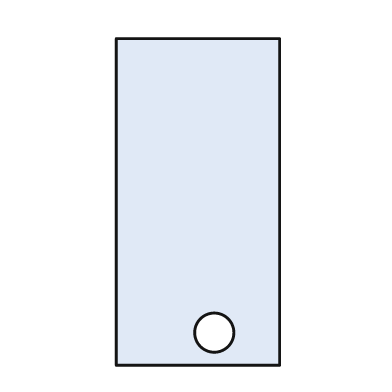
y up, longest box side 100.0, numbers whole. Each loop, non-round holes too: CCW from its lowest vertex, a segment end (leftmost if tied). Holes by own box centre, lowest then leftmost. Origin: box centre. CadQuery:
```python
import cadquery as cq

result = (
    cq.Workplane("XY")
    .moveTo(-25.0, -50.0)
    .lineTo(25.0, -50.0)
    .lineTo(25.0, 50.0)
    .lineTo(-25.0, 50.0)
    .close()
    .moveTo(5.0, -40.0)
    .circle(6.0)
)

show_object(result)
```